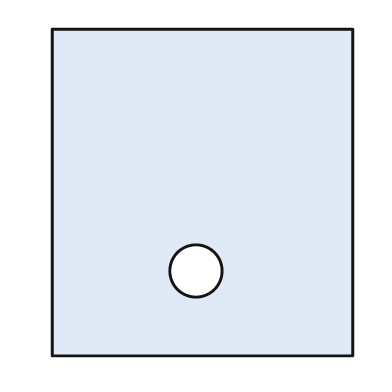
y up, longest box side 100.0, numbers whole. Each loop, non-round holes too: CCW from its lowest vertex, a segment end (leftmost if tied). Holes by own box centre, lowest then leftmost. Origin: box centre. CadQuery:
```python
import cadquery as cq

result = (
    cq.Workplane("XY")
    .moveTo(-46.0, -50.0)
    .lineTo(46.0, -50.0)
    .lineTo(46.0, 50.0)
    .lineTo(-46.0, 50.0)
    .close()
    .moveTo(-2.0, -24.0)
    .circle(8.0)
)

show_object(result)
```